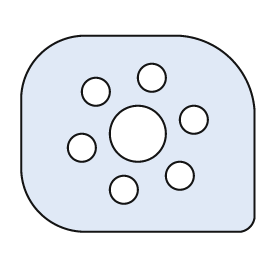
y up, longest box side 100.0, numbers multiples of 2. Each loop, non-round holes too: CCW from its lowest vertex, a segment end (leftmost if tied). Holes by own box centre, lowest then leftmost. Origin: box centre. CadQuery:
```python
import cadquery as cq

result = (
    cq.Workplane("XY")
    .moveTo(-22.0, -42.0)
    .lineTo(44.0, -42.0)
    .threePointArc((48.0, -40.0), (50.0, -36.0))
    .lineTo(50.0, 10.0)
    .threePointArc((40.0, 32.0), (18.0, 42.0))
    .lineTo(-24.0, 42.0)
    .threePointArc((-42.0, 34.0), (-50.0, 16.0))
    .lineTo(-50.0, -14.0)
    .threePointArc((-42.0, -34.0), (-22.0, -42.0))
    .close()
    .moveTo(-6.0, -24.0)
    .circle(6.0)
    .moveTo(18.0, -18.0)
    .circle(6.0)
    .moveTo(-24.0, -6.0)
    .circle(6.0)
    .moveTo(0.0, 0.0)
    .circle(12.0)
    .moveTo(24.0, 6.0)
    .circle(6.0)
    .moveTo(-18.0, 18.0)
    .circle(6.0)
    .moveTo(6.0, 24.0)
    .circle(6.0)
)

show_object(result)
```